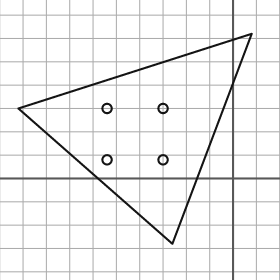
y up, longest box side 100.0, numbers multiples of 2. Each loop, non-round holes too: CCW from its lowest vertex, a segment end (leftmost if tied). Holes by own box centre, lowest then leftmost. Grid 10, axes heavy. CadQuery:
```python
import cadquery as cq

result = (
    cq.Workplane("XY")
    .moveTo(-26.0, -28.0)
    .lineTo(8.0, 62.0)
    .lineTo(-92.0, 30.0)
    .close()
    .moveTo(-54.0, 8.0)
    .circle(2.0)
    .moveTo(-30.0, 8.0)
    .circle(2.0)
    .moveTo(-54.0, 30.0)
    .circle(2.0)
    .moveTo(-30.0, 30.0)
    .circle(2.0)
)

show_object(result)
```